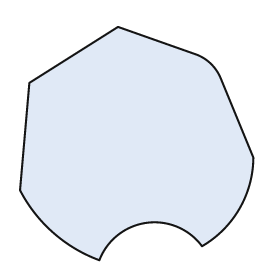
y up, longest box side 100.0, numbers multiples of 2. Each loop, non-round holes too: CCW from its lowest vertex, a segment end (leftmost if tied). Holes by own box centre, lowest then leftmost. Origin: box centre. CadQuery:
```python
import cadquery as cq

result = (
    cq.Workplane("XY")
    .moveTo(-16.0, -50.0)
    .threePointArc((4.0, -34.0), (28.0, -44.0))
    .threePointArc((44.0, -28.0), (50.0, -6.0))
    .lineTo(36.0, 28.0)
    .threePointArc((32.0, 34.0), (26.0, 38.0))
    .lineTo(-8.0, 50.0)
    .lineTo(-46.0, 26.0)
    .lineTo(-50.0, -20.0)
    .threePointArc((-36.0, -38.0), (-16.0, -50.0))
    .close()
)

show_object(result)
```